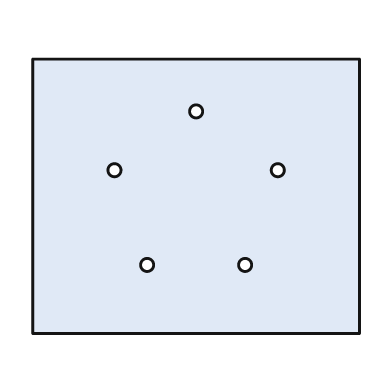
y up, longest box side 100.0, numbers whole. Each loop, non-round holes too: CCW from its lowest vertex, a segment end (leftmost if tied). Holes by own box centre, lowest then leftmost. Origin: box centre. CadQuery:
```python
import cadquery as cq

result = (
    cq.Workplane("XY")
    .moveTo(-50.0, -42.0)
    .lineTo(50.0, -42.0)
    .lineTo(50.0, 42.0)
    .lineTo(-50.0, 42.0)
    .close()
    .moveTo(-15.0, -21.0)
    .circle(2.0)
    .moveTo(15.0, -21.0)
    .circle(2.0)
    .moveTo(-25.0, 8.0)
    .circle(2.0)
    .moveTo(25.0, 8.0)
    .circle(2.0)
    .moveTo(0.0, 26.0)
    .circle(2.0)
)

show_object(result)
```